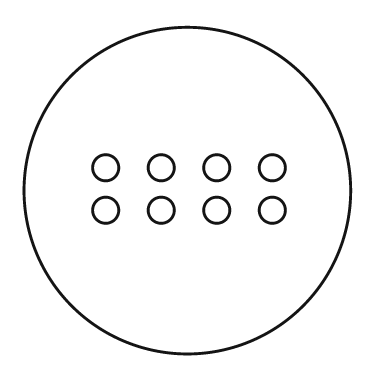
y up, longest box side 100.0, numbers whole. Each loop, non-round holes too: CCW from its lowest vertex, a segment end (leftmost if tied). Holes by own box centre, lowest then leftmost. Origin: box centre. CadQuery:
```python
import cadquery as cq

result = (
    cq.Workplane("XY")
    .moveTo(0.0, 0.0)
    .circle(50.0)
    .moveTo(-25.0, -6.0)
    .circle(4.0)
    .moveTo(-8.0, -6.0)
    .circle(4.0)
    .moveTo(9.0, -6.0)
    .circle(4.0)
    .moveTo(26.0, -6.0)
    .circle(4.0)
    .moveTo(-25.0, 7.0)
    .circle(4.0)
    .moveTo(-8.0, 7.0)
    .circle(4.0)
    .moveTo(9.0, 7.0)
    .circle(4.0)
    .moveTo(26.0, 7.0)
    .circle(4.0)
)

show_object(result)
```